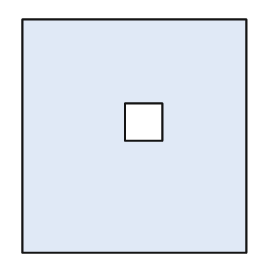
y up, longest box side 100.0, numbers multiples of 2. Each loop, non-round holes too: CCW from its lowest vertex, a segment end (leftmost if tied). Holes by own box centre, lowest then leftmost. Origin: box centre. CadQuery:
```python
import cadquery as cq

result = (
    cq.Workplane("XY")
    .moveTo(-48.0, -50.0)
    .lineTo(48.0, -50.0)
    .lineTo(48.0, 50.0)
    .lineTo(-48.0, 50.0)
    .close()
    .moveTo(-4.0, -2.0)
    .lineTo(12.0, -2.0)
    .lineTo(12.0, 14.0)
    .lineTo(-4.0, 14.0)
    .close()
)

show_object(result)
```